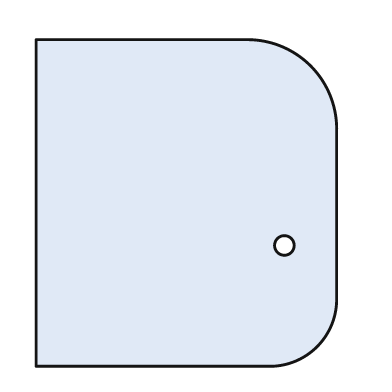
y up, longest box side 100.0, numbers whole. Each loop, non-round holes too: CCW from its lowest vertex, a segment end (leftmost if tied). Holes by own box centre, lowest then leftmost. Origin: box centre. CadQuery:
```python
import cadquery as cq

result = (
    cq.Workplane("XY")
    .moveTo(-46.0, -50.0)
    .lineTo(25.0, -50.0)
    .threePointArc((40.0, -44.0), (46.0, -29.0))
    .lineTo(46.0, 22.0)
    .threePointArc((38.0, 42.0), (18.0, 50.0))
    .lineTo(-46.0, 50.0)
    .close()
    .moveTo(30.0, -13.0)
    .circle(3.0)
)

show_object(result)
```